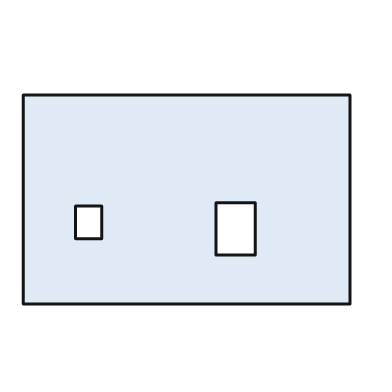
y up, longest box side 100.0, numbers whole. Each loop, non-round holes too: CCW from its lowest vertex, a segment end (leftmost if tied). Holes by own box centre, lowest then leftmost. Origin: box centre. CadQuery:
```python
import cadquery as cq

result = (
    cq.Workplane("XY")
    .moveTo(-50.0, -32.0)
    .lineTo(50.0, -32.0)
    .lineTo(50.0, 32.0)
    .lineTo(-50.0, 32.0)
    .close()
    .moveTo(9.0, -17.0)
    .lineTo(21.0, -17.0)
    .lineTo(21.0, -1.0)
    .lineTo(9.0, -1.0)
    .close()
    .moveTo(-34.0, -12.0)
    .lineTo(-26.0, -12.0)
    .lineTo(-26.0, -2.0)
    .lineTo(-34.0, -2.0)
    .close()
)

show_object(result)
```